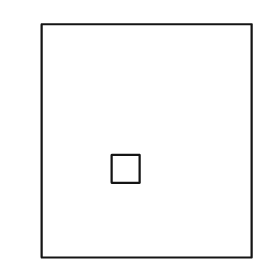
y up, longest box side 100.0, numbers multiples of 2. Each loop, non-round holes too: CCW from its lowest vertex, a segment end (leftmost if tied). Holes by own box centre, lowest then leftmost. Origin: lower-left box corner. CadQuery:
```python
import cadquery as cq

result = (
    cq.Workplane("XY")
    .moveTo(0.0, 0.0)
    .lineTo(90.0, 0.0)
    .lineTo(90.0, 100.0)
    .lineTo(0.0, 100.0)
    .close()
    .moveTo(30.0, 32.0)
    .lineTo(42.0, 32.0)
    .lineTo(42.0, 44.0)
    .lineTo(30.0, 44.0)
    .close()
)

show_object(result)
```